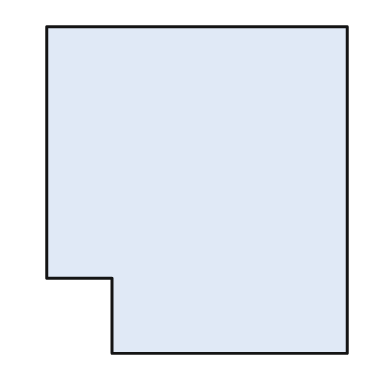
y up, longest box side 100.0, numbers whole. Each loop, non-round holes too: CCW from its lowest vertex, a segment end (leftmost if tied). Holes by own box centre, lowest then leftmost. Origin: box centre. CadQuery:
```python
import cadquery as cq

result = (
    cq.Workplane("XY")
    .moveTo(-26.0, -50.0)
    .lineTo(46.0, -50.0)
    .lineTo(46.0, 50.0)
    .lineTo(-46.0, 50.0)
    .lineTo(-46.0, -27.0)
    .lineTo(-26.0, -27.0)
    .close()
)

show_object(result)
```